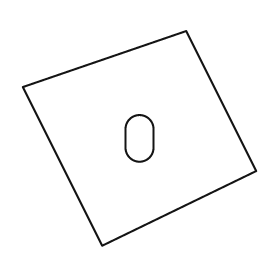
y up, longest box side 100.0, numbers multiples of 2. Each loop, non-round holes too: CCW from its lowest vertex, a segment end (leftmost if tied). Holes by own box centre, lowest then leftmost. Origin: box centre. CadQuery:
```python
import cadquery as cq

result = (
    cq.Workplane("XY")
    .moveTo(-16.0, -46.0)
    .lineTo(50.0, -14.0)
    .lineTo(20.0, 46.0)
    .lineTo(-50.0, 22.0)
    .close()
    .moveTo(-6.0, -4.0)
    .threePointArc((0.0, -10.0), (6.0, -4.0))
    .lineTo(6.0, 4.0)
    .threePointArc((0.0, 10.0), (-6.0, 4.0))
    .close()
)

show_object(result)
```